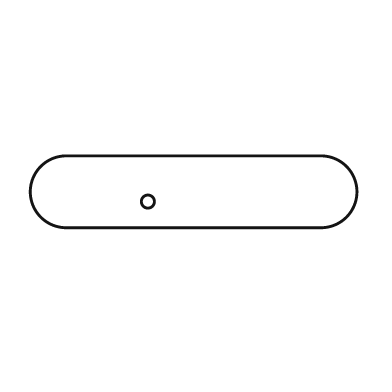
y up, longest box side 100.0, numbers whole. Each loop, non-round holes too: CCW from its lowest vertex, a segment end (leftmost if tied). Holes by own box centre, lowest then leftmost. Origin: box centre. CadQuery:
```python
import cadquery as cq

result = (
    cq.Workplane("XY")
    .moveTo(-39.0, -11.0)
    .lineTo(39.0, -11.0)
    .threePointArc((50.0, 0.0), (39.0, 11.0))
    .lineTo(-39.0, 11.0)
    .threePointArc((-50.0, 0.0), (-39.0, -11.0))
    .close()
    .moveTo(-14.0, -3.0)
    .circle(2.0)
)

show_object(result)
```